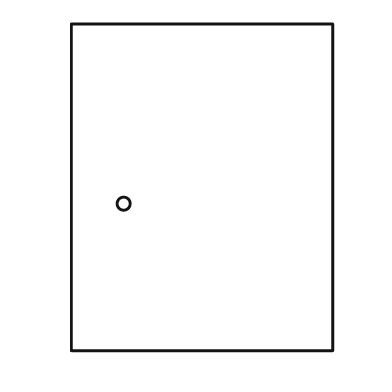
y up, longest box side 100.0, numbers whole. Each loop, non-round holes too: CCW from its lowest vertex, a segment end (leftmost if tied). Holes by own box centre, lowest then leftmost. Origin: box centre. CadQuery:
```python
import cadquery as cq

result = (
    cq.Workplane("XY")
    .moveTo(-40.0, -50.0)
    .lineTo(40.0, -50.0)
    .lineTo(40.0, 50.0)
    .lineTo(-40.0, 50.0)
    .close()
    .moveTo(-24.0, -5.0)
    .circle(2.0)
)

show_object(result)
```